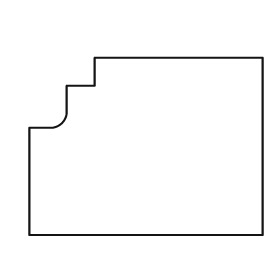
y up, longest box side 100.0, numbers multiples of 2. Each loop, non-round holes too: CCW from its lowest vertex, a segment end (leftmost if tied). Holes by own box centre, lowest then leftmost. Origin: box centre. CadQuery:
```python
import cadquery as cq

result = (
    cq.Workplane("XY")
    .moveTo(-50.0, -38.0)
    .lineTo(50.0, -38.0)
    .lineTo(50.0, 38.0)
    .lineTo(-22.0, 38.0)
    .lineTo(-22.0, 26.0)
    .lineTo(-34.0, 26.0)
    .lineTo(-34.0, 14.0)
    .threePointArc((-36.0, 10.0), (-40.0, 8.0))
    .lineTo(-50.0, 8.0)
    .close()
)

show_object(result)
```